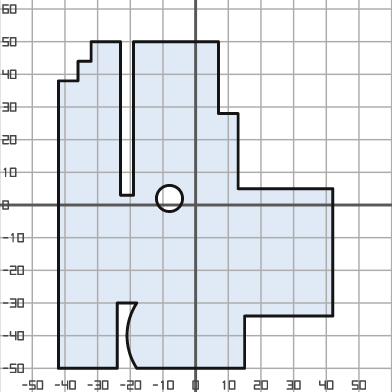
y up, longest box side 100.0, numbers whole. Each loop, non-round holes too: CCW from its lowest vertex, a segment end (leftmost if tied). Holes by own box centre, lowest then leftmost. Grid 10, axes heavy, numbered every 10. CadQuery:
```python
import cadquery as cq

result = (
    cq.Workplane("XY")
    .moveTo(-42.0, -50.0)
    .lineTo(-24.0, -50.0)
    .lineTo(-24.0, -30.0)
    .lineTo(-18.0, -30.0)
    .threePointArc((-21.0, -40.0), (-18.0, -50.0))
    .lineTo(15.0, -50.0)
    .lineTo(15.0, -34.0)
    .lineTo(42.0, -34.0)
    .lineTo(42.0, 5.0)
    .lineTo(13.0, 5.0)
    .lineTo(13.0, 28.0)
    .lineTo(7.0, 28.0)
    .lineTo(7.0, 50.0)
    .lineTo(-19.0, 50.0)
    .lineTo(-19.0, 3.0)
    .lineTo(-23.0, 3.0)
    .lineTo(-23.0, 50.0)
    .lineTo(-32.0, 50.0)
    .lineTo(-32.0, 44.0)
    .lineTo(-36.0, 44.0)
    .lineTo(-36.0, 38.0)
    .lineTo(-42.0, 38.0)
    .close()
    .moveTo(-8.0, 2.0)
    .circle(4.0)
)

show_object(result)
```